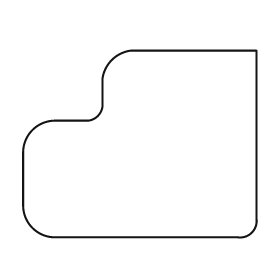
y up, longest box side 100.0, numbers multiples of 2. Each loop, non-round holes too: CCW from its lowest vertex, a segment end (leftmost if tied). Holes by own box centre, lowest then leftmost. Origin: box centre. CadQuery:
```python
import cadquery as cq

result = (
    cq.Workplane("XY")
    .moveTo(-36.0, -40.0)
    .lineTo(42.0, -40.0)
    .threePointArc((48.0, -38.0), (50.0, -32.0))
    .lineTo(50.0, 40.0)
    .lineTo(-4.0, 40.0)
    .threePointArc((-12.0, 36.0), (-16.0, 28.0))
    .lineTo(-16.0, 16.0)
    .threePointArc((-18.0, 12.0), (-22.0, 10.0))
    .lineTo(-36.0, 10.0)
    .threePointArc((-46.0, 6.0), (-50.0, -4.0))
    .lineTo(-50.0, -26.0)
    .threePointArc((-46.0, -36.0), (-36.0, -40.0))
    .close()
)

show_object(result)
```